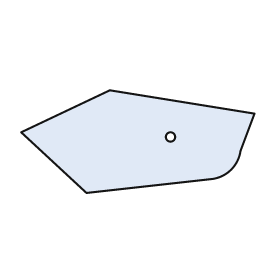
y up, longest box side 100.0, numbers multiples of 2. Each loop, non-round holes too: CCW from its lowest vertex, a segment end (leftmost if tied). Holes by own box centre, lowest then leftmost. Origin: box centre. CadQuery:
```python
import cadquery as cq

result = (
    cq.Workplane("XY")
    .moveTo(-22.0, -22.0)
    .lineTo(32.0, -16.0)
    .threePointArc((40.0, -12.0), (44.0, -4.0))
    .lineTo(50.0, 12.0)
    .lineTo(-12.0, 22.0)
    .lineTo(-50.0, 4.0)
    .close()
    .moveTo(14.0, 2.0)
    .circle(2.0)
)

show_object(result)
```